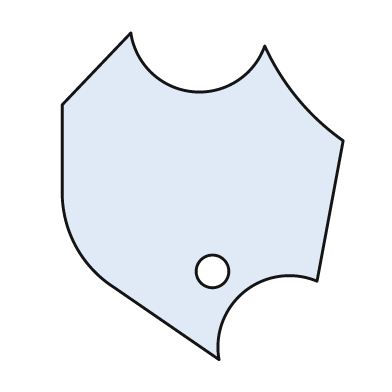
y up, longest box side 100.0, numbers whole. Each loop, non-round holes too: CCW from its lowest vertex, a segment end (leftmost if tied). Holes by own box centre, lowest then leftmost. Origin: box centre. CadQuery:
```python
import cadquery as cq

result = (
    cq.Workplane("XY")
    .moveTo(5.0, -50.0)
    .threePointArc((13.0, -29.0), (35.0, -26.0))
    .lineTo(43.0, 17.0)
    .threePointArc((29.0, 30.0), (19.0, 46.0))
    .threePointArc((-3.0, 32.0), (-22.0, 50.0))
    .lineTo(-43.0, 28.0)
    .lineTo(-43.0, 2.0)
    .threePointArc((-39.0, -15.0), (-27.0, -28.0))
    .close()
    .moveTo(3.0, -23.0)
    .circle(5.0)
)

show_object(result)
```